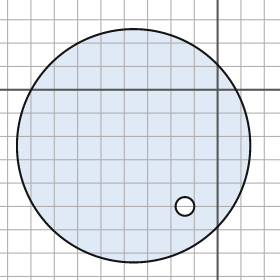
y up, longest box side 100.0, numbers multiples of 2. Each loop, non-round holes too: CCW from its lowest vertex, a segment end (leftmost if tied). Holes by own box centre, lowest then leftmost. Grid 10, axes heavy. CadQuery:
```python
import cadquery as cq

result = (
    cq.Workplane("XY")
    .moveTo(-36.0, -24.0)
    .circle(50.0)
    .moveTo(-14.0, -50.0)
    .circle(4.0)
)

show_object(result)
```